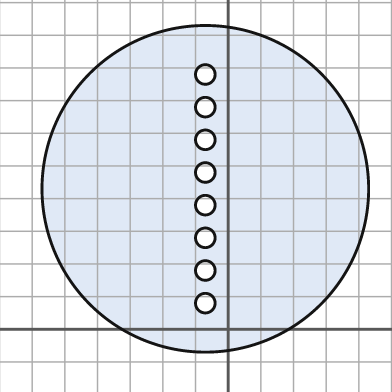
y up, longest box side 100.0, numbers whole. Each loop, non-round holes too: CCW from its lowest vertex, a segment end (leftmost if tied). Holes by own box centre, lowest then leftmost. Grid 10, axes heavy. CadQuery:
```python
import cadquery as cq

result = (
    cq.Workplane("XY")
    .moveTo(-7.0, 43.0)
    .circle(50.0)
    .moveTo(-7.0, 8.0)
    .circle(3.0)
    .moveTo(-7.0, 18.0)
    .circle(3.0)
    .moveTo(-7.0, 28.0)
    .circle(3.0)
    .moveTo(-7.0, 38.0)
    .circle(3.0)
    .moveTo(-7.0, 48.0)
    .circle(3.0)
    .moveTo(-7.0, 58.0)
    .circle(3.0)
    .moveTo(-7.0, 68.0)
    .circle(3.0)
    .moveTo(-7.0, 78.0)
    .circle(3.0)
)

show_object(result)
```